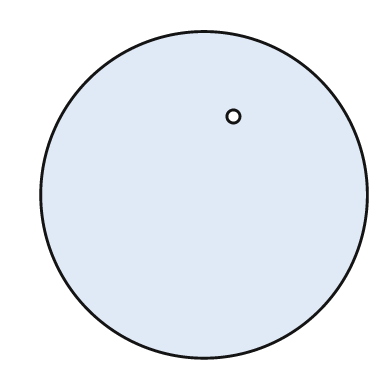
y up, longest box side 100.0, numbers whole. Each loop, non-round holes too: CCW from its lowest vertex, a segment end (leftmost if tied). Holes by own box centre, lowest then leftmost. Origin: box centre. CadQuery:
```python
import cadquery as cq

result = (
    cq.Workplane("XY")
    .moveTo(0.0, 0.0)
    .circle(50.0)
    .moveTo(9.0, 24.0)
    .circle(2.0)
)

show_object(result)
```